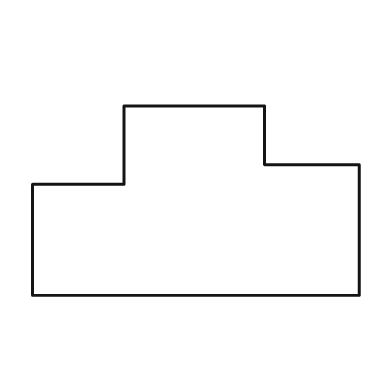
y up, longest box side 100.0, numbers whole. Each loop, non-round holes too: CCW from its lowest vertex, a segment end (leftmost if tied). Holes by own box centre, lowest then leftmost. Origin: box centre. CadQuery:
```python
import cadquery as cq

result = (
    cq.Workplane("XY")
    .moveTo(-50.0, -29.0)
    .lineTo(50.0, -29.0)
    .lineTo(50.0, 11.0)
    .lineTo(21.0, 11.0)
    .lineTo(21.0, 29.0)
    .lineTo(-22.0, 29.0)
    .lineTo(-22.0, 5.0)
    .lineTo(-50.0, 5.0)
    .close()
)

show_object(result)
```